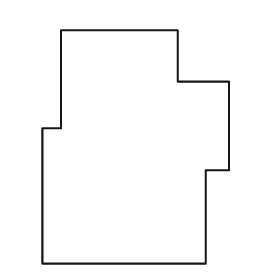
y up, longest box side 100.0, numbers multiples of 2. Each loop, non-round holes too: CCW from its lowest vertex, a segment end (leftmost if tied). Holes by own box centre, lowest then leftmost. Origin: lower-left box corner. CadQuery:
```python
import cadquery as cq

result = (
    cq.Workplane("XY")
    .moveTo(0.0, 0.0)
    .lineTo(70.0, 0.0)
    .lineTo(70.0, 40.0)
    .lineTo(80.0, 40.0)
    .lineTo(80.0, 78.0)
    .lineTo(58.0, 78.0)
    .lineTo(58.0, 100.0)
    .lineTo(8.0, 100.0)
    .lineTo(8.0, 58.0)
    .lineTo(0.0, 58.0)
    .close()
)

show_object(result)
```